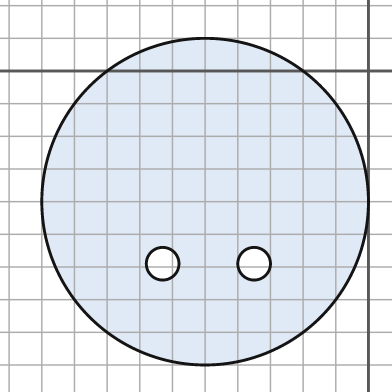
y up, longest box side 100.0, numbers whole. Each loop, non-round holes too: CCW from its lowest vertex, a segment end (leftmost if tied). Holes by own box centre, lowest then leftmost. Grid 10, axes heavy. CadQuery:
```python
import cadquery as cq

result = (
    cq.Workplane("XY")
    .moveTo(-50.0, -40.0)
    .circle(50.0)
    .moveTo(-63.0, -59.0)
    .circle(5.0)
    .moveTo(-35.0, -59.0)
    .circle(5.0)
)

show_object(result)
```